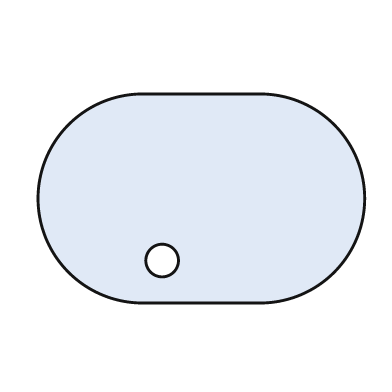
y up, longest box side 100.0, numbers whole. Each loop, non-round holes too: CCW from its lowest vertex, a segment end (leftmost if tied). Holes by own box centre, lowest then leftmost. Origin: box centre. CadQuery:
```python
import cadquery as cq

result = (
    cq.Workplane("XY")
    .moveTo(-18.0, -32.0)
    .lineTo(18.0, -32.0)
    .threePointArc((50.0, 0.0), (18.0, 32.0))
    .lineTo(-18.0, 32.0)
    .threePointArc((-50.0, 0.0), (-18.0, -32.0))
    .close()
    .moveTo(-12.0, -19.0)
    .circle(5.0)
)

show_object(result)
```